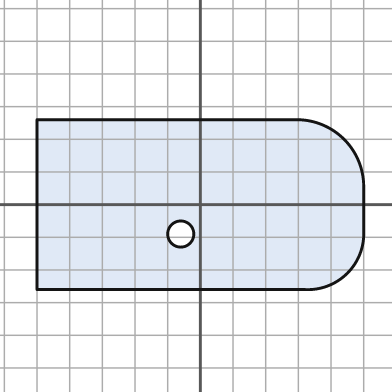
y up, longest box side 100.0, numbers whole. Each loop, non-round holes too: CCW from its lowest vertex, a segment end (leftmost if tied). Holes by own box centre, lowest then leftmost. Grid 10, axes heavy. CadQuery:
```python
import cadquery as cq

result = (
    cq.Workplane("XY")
    .moveTo(-50.0, -26.0)
    .lineTo(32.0, -26.0)
    .threePointArc((45.0, -21.0), (50.0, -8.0))
    .lineTo(50.0, 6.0)
    .threePointArc((44.0, 20.0), (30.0, 26.0))
    .lineTo(-50.0, 26.0)
    .close()
    .moveTo(-6.0, -9.0)
    .circle(4.0)
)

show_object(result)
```